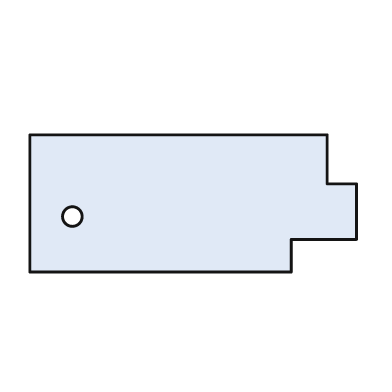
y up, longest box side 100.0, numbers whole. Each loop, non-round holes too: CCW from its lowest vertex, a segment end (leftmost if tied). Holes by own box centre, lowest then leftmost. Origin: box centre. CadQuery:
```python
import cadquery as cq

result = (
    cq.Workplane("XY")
    .moveTo(-50.0, -21.0)
    .lineTo(30.0, -21.0)
    .lineTo(30.0, -11.0)
    .lineTo(50.0, -11.0)
    .lineTo(50.0, 6.0)
    .lineTo(41.0, 6.0)
    .lineTo(41.0, 21.0)
    .lineTo(-50.0, 21.0)
    .close()
    .moveTo(-37.0, -4.0)
    .circle(3.0)
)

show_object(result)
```